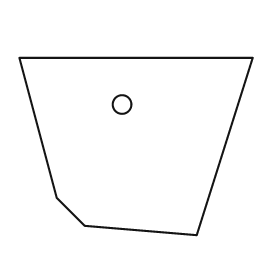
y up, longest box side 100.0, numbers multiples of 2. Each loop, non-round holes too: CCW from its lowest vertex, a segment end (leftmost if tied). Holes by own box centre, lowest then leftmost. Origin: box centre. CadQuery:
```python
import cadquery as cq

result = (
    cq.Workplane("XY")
    .moveTo(26.0, -38.0)
    .lineTo(50.0, 38.0)
    .lineTo(-50.0, 38.0)
    .lineTo(-34.0, -22.0)
    .lineTo(-22.0, -34.0)
    .close()
    .moveTo(-6.0, 18.0)
    .circle(4.0)
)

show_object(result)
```